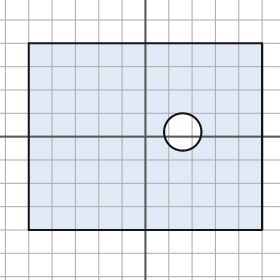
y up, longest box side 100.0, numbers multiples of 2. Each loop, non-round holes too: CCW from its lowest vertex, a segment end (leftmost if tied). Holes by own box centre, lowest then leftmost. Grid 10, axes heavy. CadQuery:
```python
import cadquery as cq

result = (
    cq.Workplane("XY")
    .moveTo(-50.0, -40.0)
    .lineTo(50.0, -40.0)
    .lineTo(50.0, 40.0)
    .lineTo(-50.0, 40.0)
    .close()
    .moveTo(16.0, 2.0)
    .circle(8.0)
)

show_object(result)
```